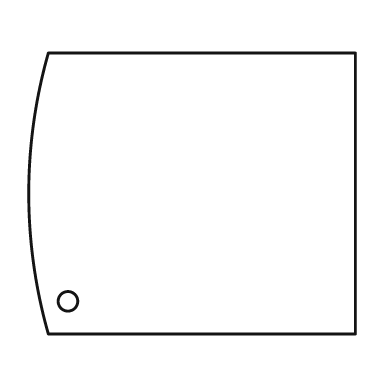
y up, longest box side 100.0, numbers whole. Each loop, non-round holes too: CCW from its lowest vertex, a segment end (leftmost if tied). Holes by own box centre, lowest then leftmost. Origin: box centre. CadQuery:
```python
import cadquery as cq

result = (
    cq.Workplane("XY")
    .moveTo(-44.0, -43.0)
    .lineTo(50.0, -43.0)
    .lineTo(50.0, 43.0)
    .lineTo(-44.0, 43.0)
    .threePointArc((-50.0, 0.0), (-44.0, -43.0))
    .close()
    .moveTo(-38.0, -33.0)
    .circle(3.0)
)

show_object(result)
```